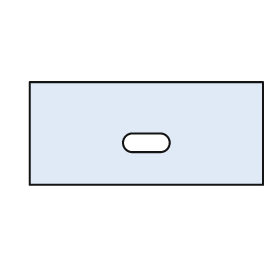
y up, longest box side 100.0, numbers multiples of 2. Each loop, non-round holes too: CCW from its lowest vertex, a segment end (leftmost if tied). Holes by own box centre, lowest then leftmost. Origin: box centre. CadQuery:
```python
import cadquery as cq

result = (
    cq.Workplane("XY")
    .moveTo(-50.0, -22.0)
    .lineTo(50.0, -22.0)
    .lineTo(50.0, 22.0)
    .lineTo(-50.0, 22.0)
    .close()
    .moveTo(-6.0, -8.0)
    .lineTo(6.0, -8.0)
    .threePointArc((10.0, -4.0), (6.0, 0.0))
    .lineTo(-6.0, 0.0)
    .threePointArc((-10.0, -4.0), (-6.0, -8.0))
    .close()
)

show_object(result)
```